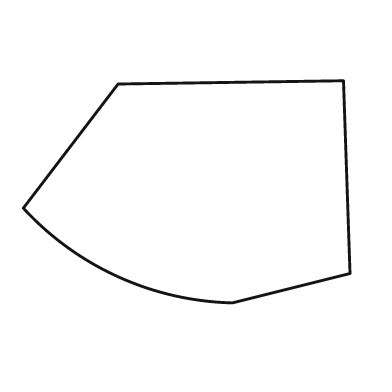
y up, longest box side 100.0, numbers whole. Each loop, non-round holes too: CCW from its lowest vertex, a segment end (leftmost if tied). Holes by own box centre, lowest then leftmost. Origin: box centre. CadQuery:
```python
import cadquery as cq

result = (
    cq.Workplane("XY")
    .moveTo(14.0, -34.0)
    .lineTo(50.0, -25.0)
    .lineTo(48.0, 34.0)
    .lineTo(-21.0, 33.0)
    .lineTo(-50.0, -5.0)
    .threePointArc((-21.0, -26.0), (14.0, -34.0))
    .close()
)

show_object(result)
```